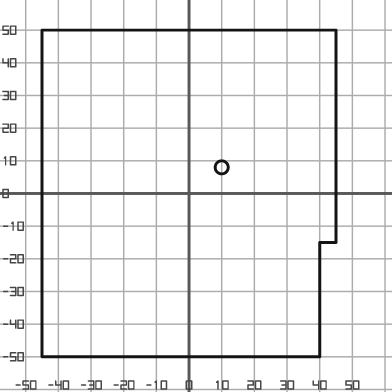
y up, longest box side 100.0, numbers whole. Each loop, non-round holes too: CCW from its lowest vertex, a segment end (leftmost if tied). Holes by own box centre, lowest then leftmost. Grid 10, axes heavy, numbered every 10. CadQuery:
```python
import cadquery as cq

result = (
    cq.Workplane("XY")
    .moveTo(-45.0, -50.0)
    .lineTo(40.0, -50.0)
    .lineTo(40.0, -15.0)
    .lineTo(45.0, -15.0)
    .lineTo(45.0, 50.0)
    .lineTo(-45.0, 50.0)
    .close()
    .moveTo(10.0, 8.0)
    .circle(2.0)
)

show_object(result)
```